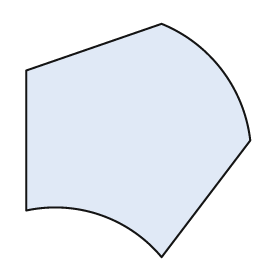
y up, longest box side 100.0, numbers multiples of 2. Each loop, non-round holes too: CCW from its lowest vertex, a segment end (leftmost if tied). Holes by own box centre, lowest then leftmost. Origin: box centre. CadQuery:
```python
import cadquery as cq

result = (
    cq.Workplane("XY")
    .moveTo(10.0, -50.0)
    .lineTo(48.0, 0.0)
    .threePointArc((36.0, 30.0), (10.0, 50.0))
    .lineTo(-48.0, 30.0)
    .lineTo(-48.0, -30.0)
    .threePointArc((-16.0, -32.0), (10.0, -50.0))
    .close()
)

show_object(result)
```